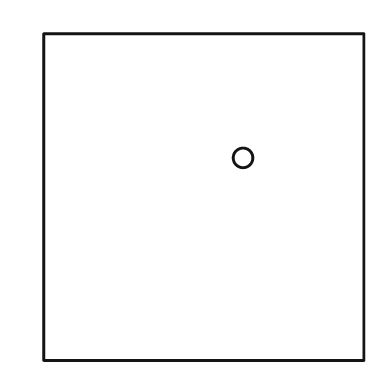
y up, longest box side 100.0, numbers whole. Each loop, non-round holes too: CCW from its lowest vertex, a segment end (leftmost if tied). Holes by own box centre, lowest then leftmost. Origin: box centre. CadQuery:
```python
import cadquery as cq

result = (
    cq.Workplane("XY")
    .moveTo(-49.0, -50.0)
    .lineTo(49.0, -50.0)
    .lineTo(49.0, 50.0)
    .lineTo(-49.0, 50.0)
    .close()
    .moveTo(12.0, 12.0)
    .circle(3.0)
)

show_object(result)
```